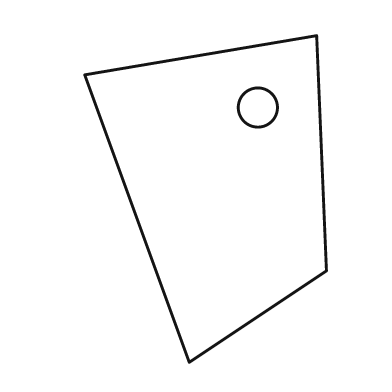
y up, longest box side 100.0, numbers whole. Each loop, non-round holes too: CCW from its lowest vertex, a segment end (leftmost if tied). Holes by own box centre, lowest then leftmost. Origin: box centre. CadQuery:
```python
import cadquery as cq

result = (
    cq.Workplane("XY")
    .moveTo(-5.0, -50.0)
    .lineTo(37.0, -22.0)
    .lineTo(34.0, 50.0)
    .lineTo(-37.0, 38.0)
    .close()
    .moveTo(16.0, 28.0)
    .circle(6.0)
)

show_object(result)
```